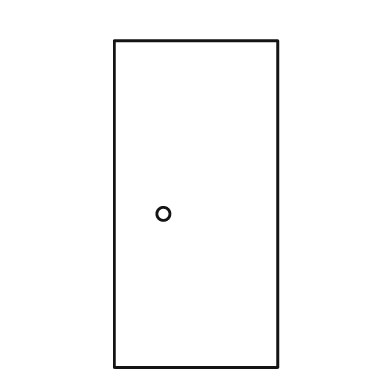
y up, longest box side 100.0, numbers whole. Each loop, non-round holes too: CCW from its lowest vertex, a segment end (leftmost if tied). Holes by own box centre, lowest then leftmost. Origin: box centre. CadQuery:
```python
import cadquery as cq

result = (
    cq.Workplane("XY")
    .moveTo(-25.0, -50.0)
    .lineTo(25.0, -50.0)
    .lineTo(25.0, 50.0)
    .lineTo(-25.0, 50.0)
    .close()
    .moveTo(-10.0, -3.0)
    .circle(2.0)
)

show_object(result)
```